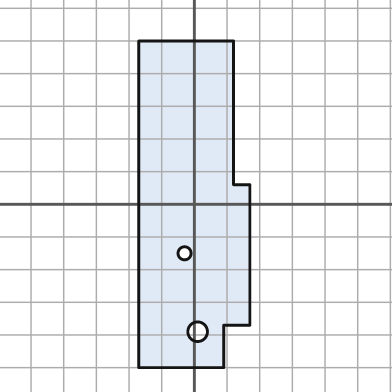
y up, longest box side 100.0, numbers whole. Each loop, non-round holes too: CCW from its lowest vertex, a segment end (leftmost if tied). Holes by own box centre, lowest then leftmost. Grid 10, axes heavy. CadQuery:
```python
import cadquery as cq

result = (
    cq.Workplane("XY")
    .moveTo(-17.0, -50.0)
    .lineTo(9.0, -50.0)
    .lineTo(9.0, -37.0)
    .lineTo(17.0, -37.0)
    .lineTo(17.0, 6.0)
    .lineTo(12.0, 6.0)
    .lineTo(12.0, 50.0)
    .lineTo(-17.0, 50.0)
    .close()
    .moveTo(1.0, -39.0)
    .circle(3.0)
    .moveTo(-3.0, -15.0)
    .circle(2.0)
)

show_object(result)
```